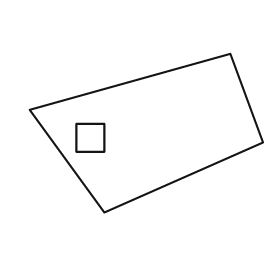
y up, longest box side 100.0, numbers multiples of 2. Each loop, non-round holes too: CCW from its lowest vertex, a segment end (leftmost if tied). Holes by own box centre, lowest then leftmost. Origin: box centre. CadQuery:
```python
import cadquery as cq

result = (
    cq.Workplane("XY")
    .moveTo(-18.0, -34.0)
    .lineTo(50.0, -4.0)
    .lineTo(36.0, 34.0)
    .lineTo(-50.0, 10.0)
    .close()
    .moveTo(-30.0, -8.0)
    .lineTo(-18.0, -8.0)
    .lineTo(-18.0, 4.0)
    .lineTo(-30.0, 4.0)
    .close()
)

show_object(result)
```